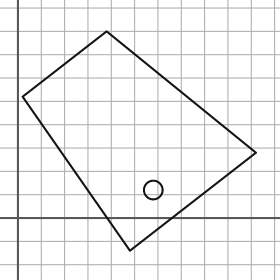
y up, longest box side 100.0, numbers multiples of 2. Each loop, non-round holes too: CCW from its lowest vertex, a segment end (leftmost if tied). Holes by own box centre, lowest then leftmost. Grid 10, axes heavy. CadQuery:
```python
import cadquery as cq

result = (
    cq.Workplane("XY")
    .moveTo(48.0, -14.0)
    .lineTo(102.0, 28.0)
    .lineTo(38.0, 80.0)
    .lineTo(2.0, 52.0)
    .close()
    .moveTo(58.0, 12.0)
    .circle(4.0)
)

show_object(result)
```